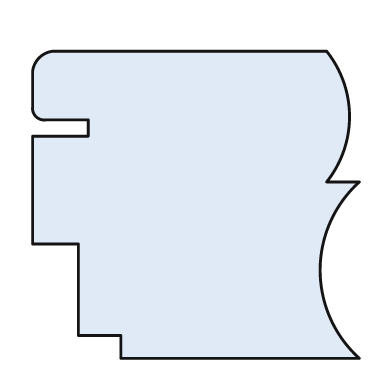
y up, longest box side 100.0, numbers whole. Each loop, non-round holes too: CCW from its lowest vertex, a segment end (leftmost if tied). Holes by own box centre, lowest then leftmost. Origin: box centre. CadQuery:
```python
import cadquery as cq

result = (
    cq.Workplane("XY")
    .moveTo(-23.0, -47.0)
    .lineTo(50.0, -47.0)
    .threePointArc((38.0, -20.0), (50.0, 7.0))
    .lineTo(40.0, 7.0)
    .threePointArc((47.0, 27.0), (40.0, 47.0))
    .lineTo(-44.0, 47.0)
    .threePointArc((-48.0, 45.0), (-50.0, 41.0))
    .lineTo(-50.0, 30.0)
    .threePointArc((-49.0, 27.0), (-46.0, 26.0))
    .lineTo(-33.0, 26.0)
    .lineTo(-33.0, 21.0)
    .lineTo(-50.0, 21.0)
    .lineTo(-50.0, -12.0)
    .lineTo(-36.0, -12.0)
    .lineTo(-36.0, -40.0)
    .lineTo(-23.0, -40.0)
    .close()
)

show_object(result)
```